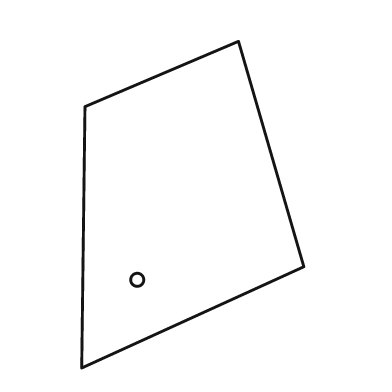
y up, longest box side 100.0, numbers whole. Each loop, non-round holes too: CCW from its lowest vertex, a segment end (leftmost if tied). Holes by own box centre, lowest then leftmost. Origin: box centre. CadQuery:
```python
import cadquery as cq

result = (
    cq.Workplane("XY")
    .moveTo(-34.0, -50.0)
    .lineTo(34.0, -19.0)
    .lineTo(14.0, 50.0)
    .lineTo(-33.0, 30.0)
    .close()
    .moveTo(-17.0, -23.0)
    .circle(2.0)
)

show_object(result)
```